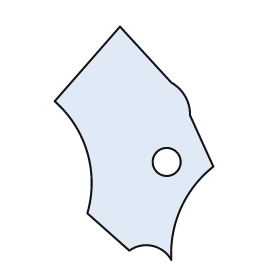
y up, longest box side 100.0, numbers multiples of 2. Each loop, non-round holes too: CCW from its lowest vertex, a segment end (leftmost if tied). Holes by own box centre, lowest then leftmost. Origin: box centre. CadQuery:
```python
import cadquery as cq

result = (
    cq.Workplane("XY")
    .moveTo(16.0, -50.0)
    .threePointArc((20.0, -28.0), (34.0, -10.0))
    .lineTo(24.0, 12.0)
    .threePointArc((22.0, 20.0), (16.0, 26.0))
    .lineTo(-6.0, 50.0)
    .lineTo(-34.0, 18.0)
    .threePointArc((-20.0, -4.0), (-20.0, -30.0))
    .lineTo(-2.0, -46.0)
    .threePointArc((8.0, -44.0), (16.0, -50.0))
    .close()
    .moveTo(14.0, -8.0)
    .circle(6.0)
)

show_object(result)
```